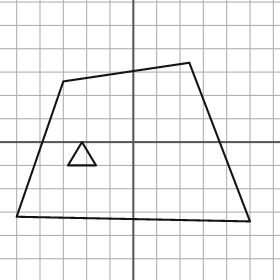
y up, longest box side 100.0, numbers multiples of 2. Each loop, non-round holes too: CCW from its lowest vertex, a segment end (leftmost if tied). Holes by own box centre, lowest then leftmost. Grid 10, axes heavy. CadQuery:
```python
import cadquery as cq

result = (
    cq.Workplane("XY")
    .moveTo(50.0, -34.0)
    .lineTo(24.0, 34.0)
    .lineTo(-30.0, 26.0)
    .lineTo(-50.0, -32.0)
    .close()
    .moveTo(-28.0, -10.0)
    .lineTo(-16.0, -10.0)
    .lineTo(-22.0, 0.0)
    .close()
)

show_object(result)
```